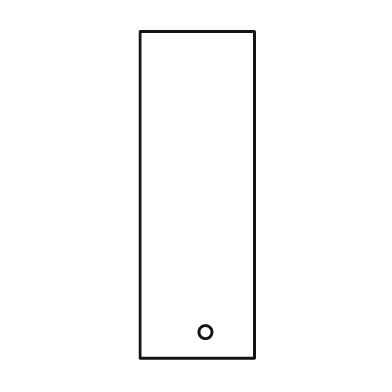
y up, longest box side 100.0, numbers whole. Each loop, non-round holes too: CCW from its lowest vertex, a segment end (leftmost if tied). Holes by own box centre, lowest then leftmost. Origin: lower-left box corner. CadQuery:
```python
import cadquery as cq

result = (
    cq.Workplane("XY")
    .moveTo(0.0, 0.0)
    .lineTo(35.0, 0.0)
    .lineTo(35.0, 100.0)
    .lineTo(0.0, 100.0)
    .close()
    .moveTo(20.0, 8.0)
    .circle(2.0)
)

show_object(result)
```